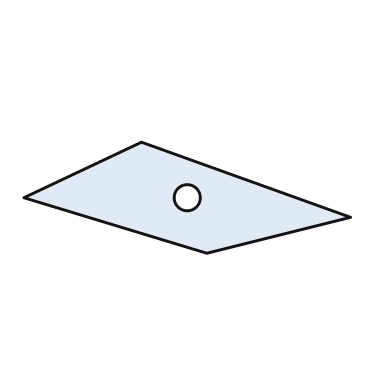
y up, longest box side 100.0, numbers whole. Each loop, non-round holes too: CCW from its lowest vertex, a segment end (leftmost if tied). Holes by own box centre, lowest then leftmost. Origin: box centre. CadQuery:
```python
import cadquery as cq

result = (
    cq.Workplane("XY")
    .moveTo(6.0, -17.0)
    .lineTo(50.0, -6.0)
    .lineTo(-14.0, 17.0)
    .lineTo(-50.0, 0.0)
    .close()
    .moveTo(0.0, 0.0)
    .circle(4.0)
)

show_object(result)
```